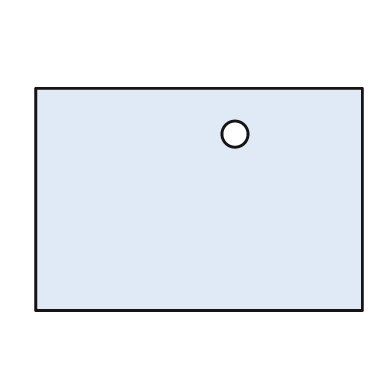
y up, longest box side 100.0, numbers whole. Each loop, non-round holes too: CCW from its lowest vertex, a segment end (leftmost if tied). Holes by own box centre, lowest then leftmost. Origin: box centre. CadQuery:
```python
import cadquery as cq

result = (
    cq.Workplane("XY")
    .moveTo(-50.0, -34.0)
    .lineTo(50.0, -34.0)
    .lineTo(50.0, 34.0)
    .lineTo(-50.0, 34.0)
    .close()
    .moveTo(11.0, 20.0)
    .circle(4.0)
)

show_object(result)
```